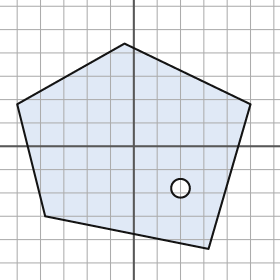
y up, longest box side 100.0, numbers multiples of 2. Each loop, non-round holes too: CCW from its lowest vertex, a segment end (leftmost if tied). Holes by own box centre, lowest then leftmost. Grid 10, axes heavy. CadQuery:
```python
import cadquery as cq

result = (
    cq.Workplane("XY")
    .moveTo(32.0, -44.0)
    .lineTo(50.0, 18.0)
    .lineTo(-4.0, 44.0)
    .lineTo(-50.0, 18.0)
    .lineTo(-38.0, -30.0)
    .close()
    .moveTo(20.0, -18.0)
    .circle(4.0)
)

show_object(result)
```